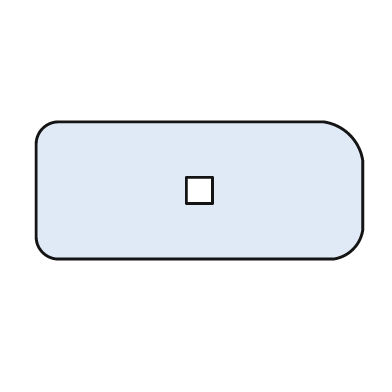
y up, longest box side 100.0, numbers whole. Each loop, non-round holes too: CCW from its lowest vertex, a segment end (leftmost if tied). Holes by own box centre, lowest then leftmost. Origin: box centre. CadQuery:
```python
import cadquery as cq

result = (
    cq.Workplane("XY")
    .moveTo(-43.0, -21.0)
    .lineTo(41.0, -21.0)
    .threePointArc((47.0, -18.0), (50.0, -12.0))
    .lineTo(50.0, 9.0)
    .threePointArc((46.0, 17.0), (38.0, 21.0))
    .lineTo(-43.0, 21.0)
    .threePointArc((-48.0, 19.0), (-50.0, 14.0))
    .lineTo(-50.0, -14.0)
    .threePointArc((-48.0, -19.0), (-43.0, -21.0))
    .close()
    .moveTo(-4.0, -4.0)
    .lineTo(4.0, -4.0)
    .lineTo(4.0, 4.0)
    .lineTo(-4.0, 4.0)
    .close()
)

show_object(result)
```